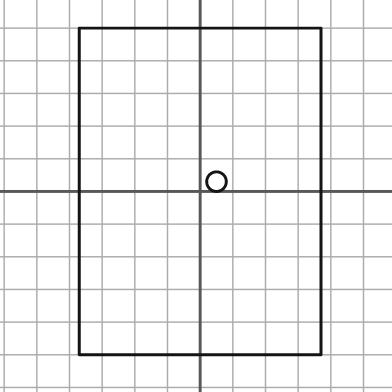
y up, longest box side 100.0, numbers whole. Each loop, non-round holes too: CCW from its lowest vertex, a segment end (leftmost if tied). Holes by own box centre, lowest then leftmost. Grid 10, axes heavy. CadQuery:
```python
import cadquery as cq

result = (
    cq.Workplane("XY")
    .moveTo(-37.0, -50.0)
    .lineTo(37.0, -50.0)
    .lineTo(37.0, 50.0)
    .lineTo(-37.0, 50.0)
    .close()
    .moveTo(5.0, 3.0)
    .circle(3.0)
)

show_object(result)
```